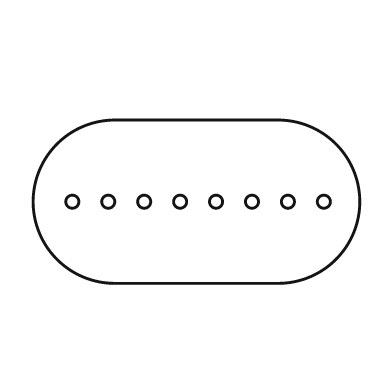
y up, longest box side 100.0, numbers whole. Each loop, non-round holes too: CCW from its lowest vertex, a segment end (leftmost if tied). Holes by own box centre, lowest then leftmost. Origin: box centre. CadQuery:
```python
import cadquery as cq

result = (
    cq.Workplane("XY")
    .moveTo(-25.0, -25.0)
    .lineTo(25.0, -25.0)
    .threePointArc((50.0, 0.0), (25.0, 25.0))
    .lineTo(-25.0, 25.0)
    .threePointArc((-50.0, 0.0), (-25.0, -25.0))
    .close()
    .moveTo(-38.0, 0.0)
    .circle(2.0)
    .moveTo(-27.0, 0.0)
    .circle(2.0)
    .moveTo(-16.0, 0.0)
    .circle(2.0)
    .moveTo(-5.0, 0.0)
    .circle(2.0)
    .moveTo(6.0, 0.0)
    .circle(2.0)
    .moveTo(17.0, 0.0)
    .circle(2.0)
    .moveTo(28.0, 0.0)
    .circle(2.0)
    .moveTo(39.0, 0.0)
    .circle(2.0)
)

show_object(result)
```